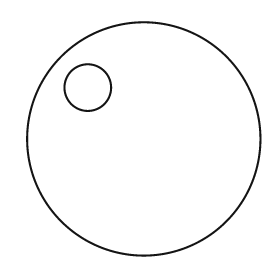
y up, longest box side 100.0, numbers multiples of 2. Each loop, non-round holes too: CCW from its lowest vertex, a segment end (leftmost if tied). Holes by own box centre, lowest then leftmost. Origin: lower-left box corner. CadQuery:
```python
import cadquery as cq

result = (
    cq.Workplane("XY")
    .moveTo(50.0, 50.0)
    .circle(50.0)
    .moveTo(26.0, 72.0)
    .circle(10.0)
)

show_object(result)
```